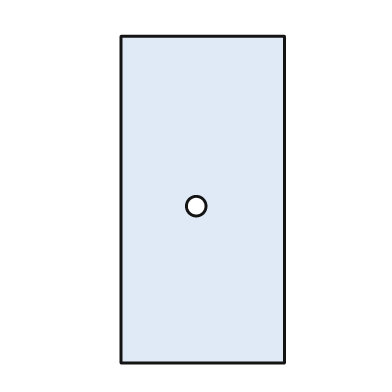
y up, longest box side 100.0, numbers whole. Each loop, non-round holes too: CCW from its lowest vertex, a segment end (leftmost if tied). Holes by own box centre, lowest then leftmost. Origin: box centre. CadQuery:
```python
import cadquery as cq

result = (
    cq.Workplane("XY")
    .moveTo(-25.0, -50.0)
    .lineTo(25.0, -50.0)
    .lineTo(25.0, 50.0)
    .lineTo(-25.0, 50.0)
    .close()
    .moveTo(-2.0, -2.0)
    .circle(3.0)
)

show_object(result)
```